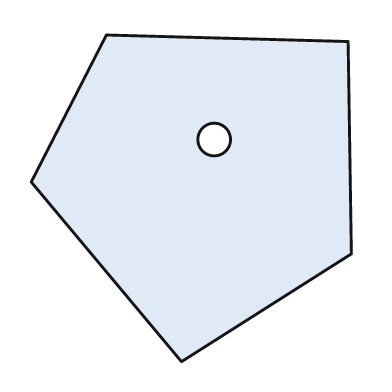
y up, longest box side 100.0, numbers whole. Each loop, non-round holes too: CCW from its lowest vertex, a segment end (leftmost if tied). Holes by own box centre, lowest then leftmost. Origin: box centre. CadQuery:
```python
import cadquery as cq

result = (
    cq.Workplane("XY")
    .moveTo(-3.0, -50.0)
    .lineTo(49.0, -17.0)
    .lineTo(48.0, 48.0)
    .lineTo(-26.0, 50.0)
    .lineTo(-49.0, 5.0)
    .close()
    .moveTo(7.0, 18.0)
    .circle(5.0)
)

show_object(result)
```